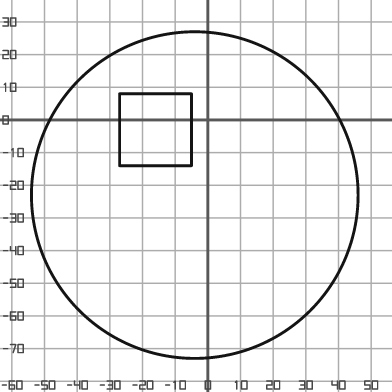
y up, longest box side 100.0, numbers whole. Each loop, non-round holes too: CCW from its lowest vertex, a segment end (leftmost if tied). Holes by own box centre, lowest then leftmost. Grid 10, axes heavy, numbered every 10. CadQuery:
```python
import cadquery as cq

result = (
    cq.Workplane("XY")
    .moveTo(-4.0, -23.0)
    .circle(50.0)
    .moveTo(-27.0, -14.0)
    .lineTo(-5.0, -14.0)
    .lineTo(-5.0, 8.0)
    .lineTo(-27.0, 8.0)
    .close()
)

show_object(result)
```